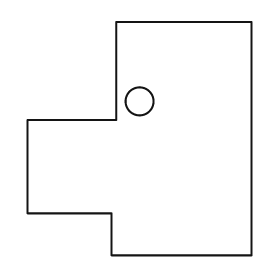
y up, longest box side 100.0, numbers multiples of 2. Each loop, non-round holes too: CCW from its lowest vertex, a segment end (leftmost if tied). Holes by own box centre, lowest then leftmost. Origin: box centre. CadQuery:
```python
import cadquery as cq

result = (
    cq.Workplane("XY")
    .moveTo(-12.0, -50.0)
    .lineTo(48.0, -50.0)
    .lineTo(48.0, 50.0)
    .lineTo(-10.0, 50.0)
    .lineTo(-10.0, 8.0)
    .lineTo(-48.0, 8.0)
    .lineTo(-48.0, -32.0)
    .lineTo(-12.0, -32.0)
    .close()
    .moveTo(0.0, 16.0)
    .circle(6.0)
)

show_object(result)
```